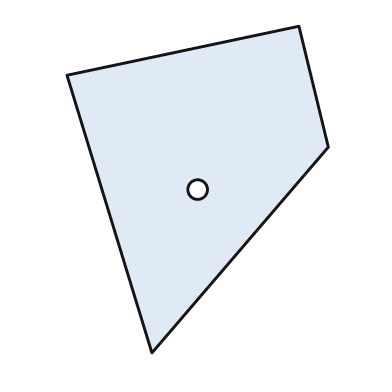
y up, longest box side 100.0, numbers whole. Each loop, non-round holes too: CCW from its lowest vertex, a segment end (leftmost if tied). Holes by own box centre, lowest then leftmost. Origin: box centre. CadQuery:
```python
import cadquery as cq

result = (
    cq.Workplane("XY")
    .moveTo(-14.0, -50.0)
    .lineTo(40.0, 13.0)
    .lineTo(31.0, 50.0)
    .lineTo(-40.0, 35.0)
    .close()
    .moveTo(0.0, 0.0)
    .circle(3.0)
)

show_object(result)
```